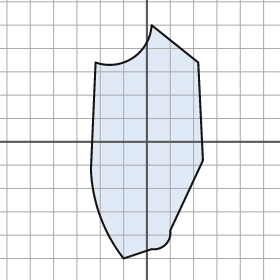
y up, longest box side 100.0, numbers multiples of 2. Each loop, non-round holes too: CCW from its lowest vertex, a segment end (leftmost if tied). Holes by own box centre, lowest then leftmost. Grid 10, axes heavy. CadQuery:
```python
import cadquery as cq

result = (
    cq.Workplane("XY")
    .moveTo(-10.0, -50.0)
    .lineTo(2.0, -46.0)
    .threePointArc((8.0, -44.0), (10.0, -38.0))
    .lineTo(24.0, -8.0)
    .lineTo(22.0, 34.0)
    .lineTo(2.0, 50.0)
    .threePointArc((-6.0, 36.0), (-22.0, 34.0))
    .lineTo(-24.0, -12.0)
    .threePointArc((-20.0, -32.0), (-10.0, -50.0))
    .close()
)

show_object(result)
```